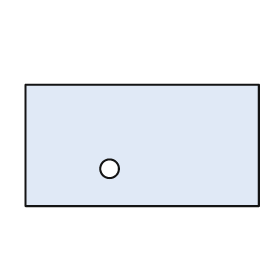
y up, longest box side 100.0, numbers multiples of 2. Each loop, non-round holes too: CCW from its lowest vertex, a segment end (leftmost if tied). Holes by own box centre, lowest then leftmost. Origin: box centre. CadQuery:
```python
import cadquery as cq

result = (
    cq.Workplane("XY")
    .moveTo(-50.0, -26.0)
    .lineTo(50.0, -26.0)
    .lineTo(50.0, 26.0)
    .lineTo(-50.0, 26.0)
    .close()
    .moveTo(-14.0, -10.0)
    .circle(4.0)
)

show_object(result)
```